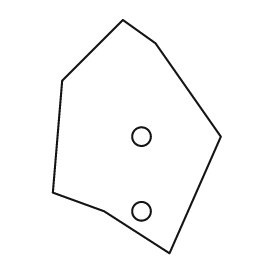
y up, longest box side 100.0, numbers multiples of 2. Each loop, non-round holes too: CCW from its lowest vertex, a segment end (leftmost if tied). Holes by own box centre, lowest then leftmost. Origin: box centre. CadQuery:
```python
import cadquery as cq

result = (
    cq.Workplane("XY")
    .moveTo(14.0, -50.0)
    .lineTo(36.0, 0.0)
    .lineTo(8.0, 40.0)
    .lineTo(-6.0, 50.0)
    .lineTo(-32.0, 24.0)
    .lineTo(-36.0, -24.0)
    .lineTo(-14.0, -32.0)
    .close()
    .moveTo(2.0, -32.0)
    .circle(4.0)
    .moveTo(2.0, 0.0)
    .circle(4.0)
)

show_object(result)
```